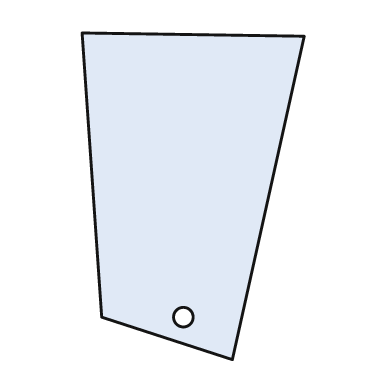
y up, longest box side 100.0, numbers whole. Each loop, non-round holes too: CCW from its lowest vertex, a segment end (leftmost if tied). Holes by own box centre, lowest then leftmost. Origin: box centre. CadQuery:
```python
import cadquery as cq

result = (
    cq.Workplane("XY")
    .moveTo(12.0, -50.0)
    .lineTo(34.0, 49.0)
    .lineTo(-34.0, 50.0)
    .lineTo(-28.0, -37.0)
    .close()
    .moveTo(-3.0, -37.0)
    .circle(3.0)
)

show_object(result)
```